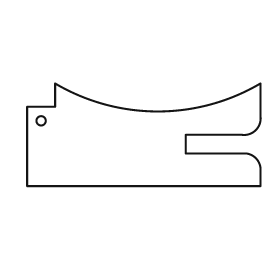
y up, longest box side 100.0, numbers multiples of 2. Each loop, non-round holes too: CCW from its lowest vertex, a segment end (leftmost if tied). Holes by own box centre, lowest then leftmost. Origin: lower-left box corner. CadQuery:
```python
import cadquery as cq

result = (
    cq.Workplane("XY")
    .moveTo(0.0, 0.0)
    .lineTo(100.0, 0.0)
    .lineTo(100.0, 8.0)
    .threePointArc((98.0, 12.0), (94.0, 14.0))
    .lineTo(68.0, 14.0)
    .lineTo(68.0, 22.0)
    .lineTo(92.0, 22.0)
    .threePointArc((98.0, 24.0), (100.0, 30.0))
    .lineTo(100.0, 44.0)
    .threePointArc((56.0, 32.0), (12.0, 44.0))
    .lineTo(12.0, 34.0)
    .lineTo(0.0, 34.0)
    .close()
    .moveTo(6.0, 28.0)
    .circle(2.0)
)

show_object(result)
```